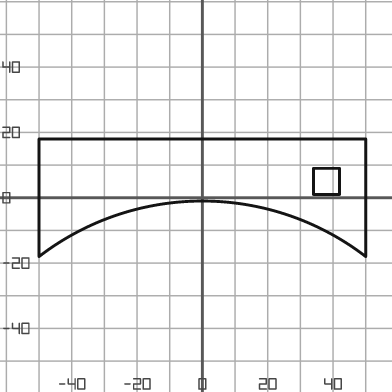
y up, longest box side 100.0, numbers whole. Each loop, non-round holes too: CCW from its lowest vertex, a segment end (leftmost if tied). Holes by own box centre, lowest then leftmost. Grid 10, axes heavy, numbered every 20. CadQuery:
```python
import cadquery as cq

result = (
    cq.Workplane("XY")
    .moveTo(-50.0, -18.0)
    .threePointArc((0.0, -1.0), (50.0, -18.0))
    .lineTo(50.0, 18.0)
    .lineTo(-50.0, 18.0)
    .close()
    .moveTo(34.0, 1.0)
    .lineTo(42.0, 1.0)
    .lineTo(42.0, 9.0)
    .lineTo(34.0, 9.0)
    .close()
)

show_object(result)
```